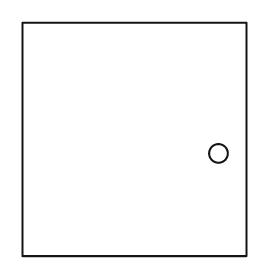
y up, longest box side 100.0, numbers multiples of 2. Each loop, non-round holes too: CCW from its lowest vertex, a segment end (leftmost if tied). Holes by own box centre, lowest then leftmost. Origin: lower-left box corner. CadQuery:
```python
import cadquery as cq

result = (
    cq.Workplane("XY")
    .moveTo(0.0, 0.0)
    .lineTo(96.0, 0.0)
    .lineTo(96.0, 100.0)
    .lineTo(0.0, 100.0)
    .close()
    .moveTo(84.0, 44.0)
    .circle(4.0)
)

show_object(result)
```